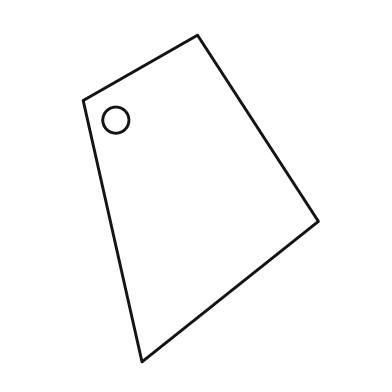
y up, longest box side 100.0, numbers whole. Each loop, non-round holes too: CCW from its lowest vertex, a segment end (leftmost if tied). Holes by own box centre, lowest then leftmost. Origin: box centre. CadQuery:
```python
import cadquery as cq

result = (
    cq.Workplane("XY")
    .moveTo(-18.0, -50.0)
    .lineTo(36.0, -7.0)
    .lineTo(-1.0, 50.0)
    .lineTo(-36.0, 30.0)
    .close()
    .moveTo(-26.0, 24.0)
    .circle(4.0)
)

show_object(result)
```